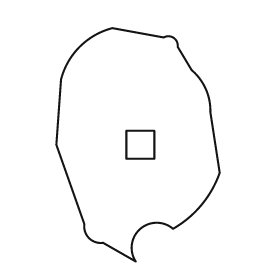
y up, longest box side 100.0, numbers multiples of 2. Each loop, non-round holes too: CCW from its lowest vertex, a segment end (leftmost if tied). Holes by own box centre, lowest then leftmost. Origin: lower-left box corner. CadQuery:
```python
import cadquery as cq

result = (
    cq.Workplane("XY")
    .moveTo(34.0, 0.0)
    .threePointArc((36.0, 14.0), (50.0, 14.0))
    .threePointArc((62.0, 24.0), (70.0, 38.0))
    .lineTo(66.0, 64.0)
    .threePointArc((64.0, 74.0), (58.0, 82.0))
    .lineTo(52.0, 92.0)
    .threePointArc((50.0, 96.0), (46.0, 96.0))
    .lineTo(24.0, 100.0)
    .threePointArc((10.0, 92.0), (2.0, 78.0))
    .lineTo(0.0, 50.0)
    .lineTo(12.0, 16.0)
    .threePointArc((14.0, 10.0), (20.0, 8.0))
    .close()
    .moveTo(30.0, 44.0)
    .lineTo(42.0, 44.0)
    .lineTo(42.0, 56.0)
    .lineTo(30.0, 56.0)
    .close()
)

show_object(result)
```